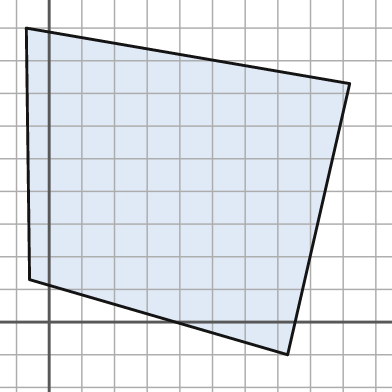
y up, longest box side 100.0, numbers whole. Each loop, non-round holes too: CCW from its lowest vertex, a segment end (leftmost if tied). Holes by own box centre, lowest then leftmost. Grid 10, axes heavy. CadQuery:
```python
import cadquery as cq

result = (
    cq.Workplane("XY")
    .moveTo(73.0, -10.0)
    .lineTo(92.0, 73.0)
    .lineTo(-7.0, 90.0)
    .lineTo(-6.0, 13.0)
    .close()
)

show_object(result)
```